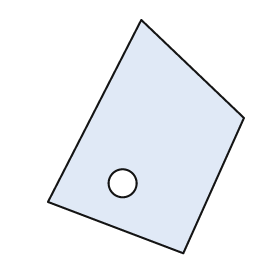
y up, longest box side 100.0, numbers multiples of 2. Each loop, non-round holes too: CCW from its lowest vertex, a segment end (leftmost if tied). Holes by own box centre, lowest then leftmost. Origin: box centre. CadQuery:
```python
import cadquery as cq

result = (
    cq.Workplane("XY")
    .moveTo(16.0, -50.0)
    .lineTo(42.0, 8.0)
    .lineTo(-2.0, 50.0)
    .lineTo(-42.0, -28.0)
    .close()
    .moveTo(-10.0, -20.0)
    .circle(6.0)
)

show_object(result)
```